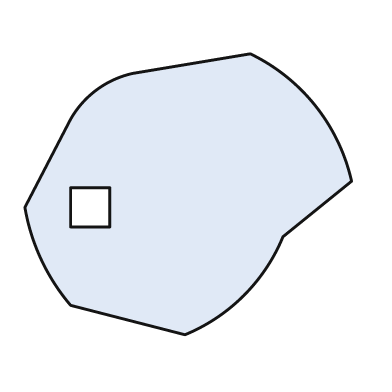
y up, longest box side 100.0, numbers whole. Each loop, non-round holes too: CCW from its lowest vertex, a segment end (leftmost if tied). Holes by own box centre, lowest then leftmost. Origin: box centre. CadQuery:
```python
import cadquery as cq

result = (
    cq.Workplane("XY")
    .moveTo(-1.0, -43.0)
    .threePointArc((17.0, -31.0), (29.0, -13.0))
    .lineTo(50.0, 4.0)
    .threePointArc((39.0, 27.0), (19.0, 43.0))
    .lineTo(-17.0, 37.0)
    .threePointArc((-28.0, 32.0), (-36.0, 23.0))
    .lineTo(-50.0, -4.0)
    .threePointArc((-45.0, -20.0), (-36.0, -34.0))
    .close()
    .moveTo(-36.0, -10.0)
    .lineTo(-24.0, -10.0)
    .lineTo(-24.0, 2.0)
    .lineTo(-36.0, 2.0)
    .close()
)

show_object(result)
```